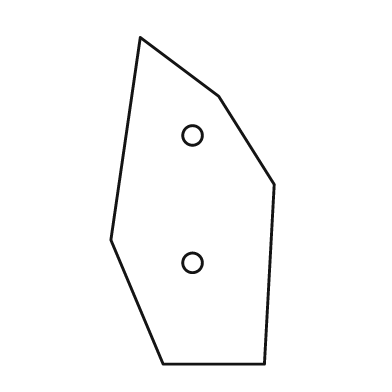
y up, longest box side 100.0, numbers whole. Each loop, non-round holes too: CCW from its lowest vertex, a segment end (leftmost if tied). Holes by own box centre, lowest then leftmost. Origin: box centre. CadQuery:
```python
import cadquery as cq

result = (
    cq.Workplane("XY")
    .moveTo(-9.0, -50.0)
    .lineTo(22.0, -50.0)
    .lineTo(25.0, 5.0)
    .lineTo(8.0, 32.0)
    .lineTo(-16.0, 50.0)
    .lineTo(-25.0, -12.0)
    .close()
    .moveTo(0.0, -19.0)
    .circle(3.0)
    .moveTo(0.0, 20.0)
    .circle(3.0)
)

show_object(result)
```